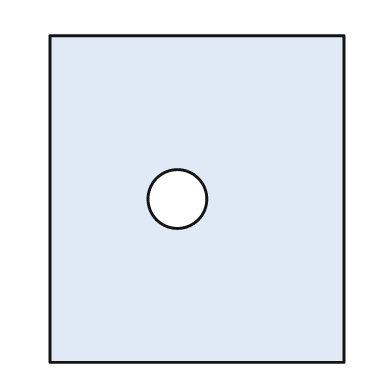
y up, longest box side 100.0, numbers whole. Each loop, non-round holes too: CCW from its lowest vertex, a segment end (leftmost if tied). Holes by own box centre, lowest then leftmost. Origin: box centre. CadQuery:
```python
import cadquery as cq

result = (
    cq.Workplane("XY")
    .moveTo(-45.0, -50.0)
    .lineTo(45.0, -50.0)
    .lineTo(45.0, 50.0)
    .lineTo(-45.0, 50.0)
    .close()
    .moveTo(-6.0, 0.0)
    .circle(9.0)
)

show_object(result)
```